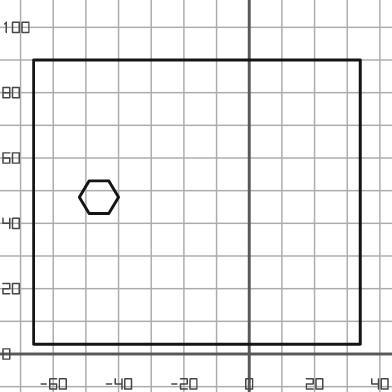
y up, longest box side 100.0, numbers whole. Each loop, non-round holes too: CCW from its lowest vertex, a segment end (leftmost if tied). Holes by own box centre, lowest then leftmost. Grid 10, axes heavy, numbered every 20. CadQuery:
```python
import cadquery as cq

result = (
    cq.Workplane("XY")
    .moveTo(-66.0, 3.0)
    .lineTo(34.0, 3.0)
    .lineTo(34.0, 90.0)
    .lineTo(-66.0, 90.0)
    .close()
    .moveTo(-49.0, 43.0)
    .lineTo(-43.0, 43.0)
    .lineTo(-40.0, 48.0)
    .lineTo(-43.0, 53.0)
    .lineTo(-49.0, 53.0)
    .lineTo(-52.0, 48.0)
    .close()
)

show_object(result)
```